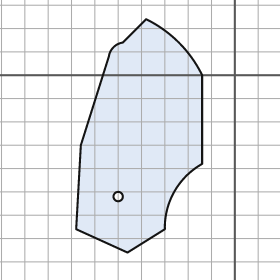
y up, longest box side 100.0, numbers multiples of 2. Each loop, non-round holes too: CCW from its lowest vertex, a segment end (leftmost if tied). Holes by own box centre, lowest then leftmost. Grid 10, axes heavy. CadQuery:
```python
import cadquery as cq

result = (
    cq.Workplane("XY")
    .moveTo(-46.0, -76.0)
    .lineTo(-30.0, -66.0)
    .threePointArc((-26.0, -50.0), (-14.0, -38.0))
    .lineTo(-14.0, 0.0)
    .threePointArc((-24.0, 14.0), (-38.0, 24.0))
    .lineTo(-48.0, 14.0)
    .threePointArc((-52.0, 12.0), (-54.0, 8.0))
    .lineTo(-66.0, -30.0)
    .lineTo(-68.0, -66.0)
    .close()
    .moveTo(-50.0, -52.0)
    .circle(2.0)
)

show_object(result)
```